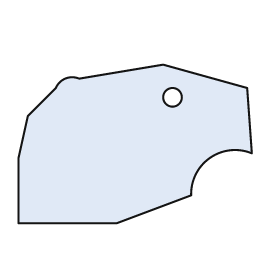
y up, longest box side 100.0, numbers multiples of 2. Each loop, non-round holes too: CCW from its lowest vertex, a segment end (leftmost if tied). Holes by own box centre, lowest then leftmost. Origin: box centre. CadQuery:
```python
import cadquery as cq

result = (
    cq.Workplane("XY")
    .moveTo(-50.0, -34.0)
    .lineTo(-8.0, -34.0)
    .lineTo(24.0, -22.0)
    .threePointArc((32.0, -6.0), (50.0, -4.0))
    .lineTo(48.0, 24.0)
    .lineTo(12.0, 34.0)
    .lineTo(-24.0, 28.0)
    .threePointArc((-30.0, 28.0), (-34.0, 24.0))
    .lineTo(-46.0, 12.0)
    .lineTo(-50.0, -6.0)
    .close()
    .moveTo(16.0, 20.0)
    .circle(4.0)
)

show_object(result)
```